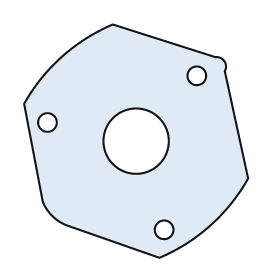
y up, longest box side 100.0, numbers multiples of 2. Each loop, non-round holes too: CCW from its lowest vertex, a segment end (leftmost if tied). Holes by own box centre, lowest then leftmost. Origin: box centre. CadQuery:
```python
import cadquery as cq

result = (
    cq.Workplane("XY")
    .moveTo(10.0, -50.0)
    .threePointArc((32.0, -36.0), (48.0, -16.0))
    .lineTo(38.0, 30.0)
    .threePointArc((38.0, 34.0), (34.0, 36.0))
    .lineTo(-10.0, 50.0)
    .threePointArc((-32.0, 36.0), (-48.0, 16.0))
    .lineTo(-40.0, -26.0)
    .threePointArc((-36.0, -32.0), (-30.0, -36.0))
    .close()
    .moveTo(12.0, -38.0)
    .circle(4.0)
    .moveTo(0.0, 0.0)
    .circle(14.0)
    .moveTo(-38.0, 8.0)
    .circle(4.0)
    .moveTo(26.0, 28.0)
    .circle(4.0)
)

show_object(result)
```